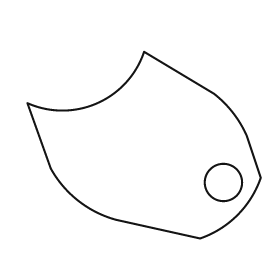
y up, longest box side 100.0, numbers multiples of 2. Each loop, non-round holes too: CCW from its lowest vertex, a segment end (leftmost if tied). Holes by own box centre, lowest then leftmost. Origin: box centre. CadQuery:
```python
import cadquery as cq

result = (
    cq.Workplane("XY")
    .moveTo(24.0, -40.0)
    .threePointArc((40.0, -30.0), (50.0, -14.0))
    .lineTo(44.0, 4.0)
    .threePointArc((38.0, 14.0), (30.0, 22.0))
    .lineTo(0.0, 40.0)
    .threePointArc((-20.0, 18.0), (-50.0, 18.0))
    .lineTo(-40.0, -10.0)
    .threePointArc((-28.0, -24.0), (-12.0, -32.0))
    .close()
    .moveTo(34.0, -16.0)
    .circle(8.0)
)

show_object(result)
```